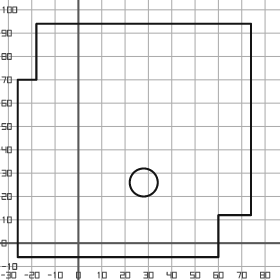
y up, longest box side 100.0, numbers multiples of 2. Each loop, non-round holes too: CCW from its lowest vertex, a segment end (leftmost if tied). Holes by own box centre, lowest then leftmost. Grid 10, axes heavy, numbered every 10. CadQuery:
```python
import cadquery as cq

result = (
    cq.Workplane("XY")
    .moveTo(-26.0, -6.0)
    .lineTo(60.0, -6.0)
    .lineTo(60.0, 12.0)
    .lineTo(74.0, 12.0)
    .lineTo(74.0, 94.0)
    .lineTo(-18.0, 94.0)
    .lineTo(-18.0, 70.0)
    .lineTo(-26.0, 70.0)
    .close()
    .moveTo(28.0, 26.0)
    .circle(6.0)
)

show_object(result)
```